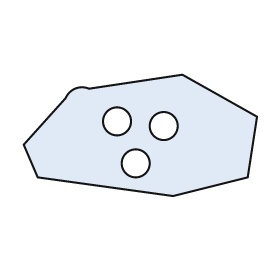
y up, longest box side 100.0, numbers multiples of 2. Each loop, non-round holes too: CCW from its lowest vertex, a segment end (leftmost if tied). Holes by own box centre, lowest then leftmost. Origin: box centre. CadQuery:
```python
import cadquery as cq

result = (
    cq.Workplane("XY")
    .moveTo(14.0, -26.0)
    .lineTo(46.0, -18.0)
    .lineTo(50.0, 8.0)
    .lineTo(18.0, 26.0)
    .lineTo(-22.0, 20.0)
    .threePointArc((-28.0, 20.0), (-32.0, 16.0))
    .lineTo(-50.0, -4.0)
    .lineTo(-44.0, -18.0)
    .close()
    .moveTo(-2.0, -12.0)
    .circle(6.0)
    .moveTo(10.0, 4.0)
    .circle(6.0)
    .moveTo(-10.0, 6.0)
    .circle(6.0)
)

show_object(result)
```